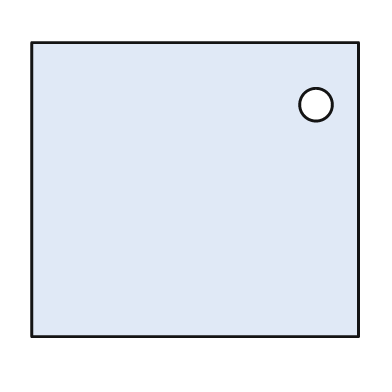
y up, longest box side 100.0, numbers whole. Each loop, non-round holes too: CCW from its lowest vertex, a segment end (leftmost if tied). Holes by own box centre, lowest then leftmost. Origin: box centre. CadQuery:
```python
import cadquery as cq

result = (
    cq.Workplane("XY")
    .moveTo(-50.0, -45.0)
    .lineTo(50.0, -45.0)
    .lineTo(50.0, 45.0)
    .lineTo(-50.0, 45.0)
    .close()
    .moveTo(37.0, 26.0)
    .circle(5.0)
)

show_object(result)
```